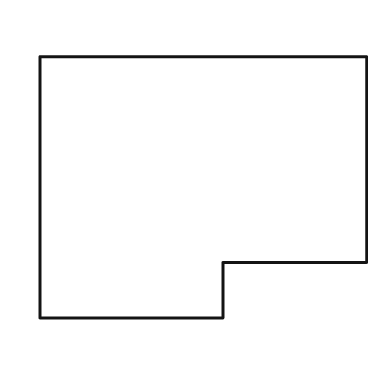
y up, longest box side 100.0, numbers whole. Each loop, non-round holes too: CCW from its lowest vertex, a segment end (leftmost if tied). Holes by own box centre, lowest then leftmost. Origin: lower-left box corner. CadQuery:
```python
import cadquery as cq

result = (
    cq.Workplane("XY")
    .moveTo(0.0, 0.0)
    .lineTo(56.0, 0.0)
    .lineTo(56.0, 17.0)
    .lineTo(100.0, 17.0)
    .lineTo(100.0, 80.0)
    .lineTo(0.0, 80.0)
    .close()
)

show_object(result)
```